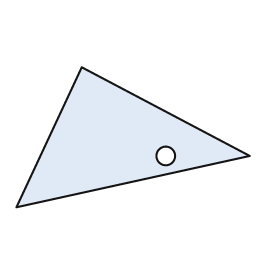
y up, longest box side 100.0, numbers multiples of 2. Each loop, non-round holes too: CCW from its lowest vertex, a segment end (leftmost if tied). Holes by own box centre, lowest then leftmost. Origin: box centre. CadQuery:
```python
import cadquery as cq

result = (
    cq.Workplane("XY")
    .moveTo(-50.0, -30.0)
    .lineTo(50.0, -8.0)
    .lineTo(-22.0, 30.0)
    .close()
    .moveTo(14.0, -8.0)
    .circle(4.0)
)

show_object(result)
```